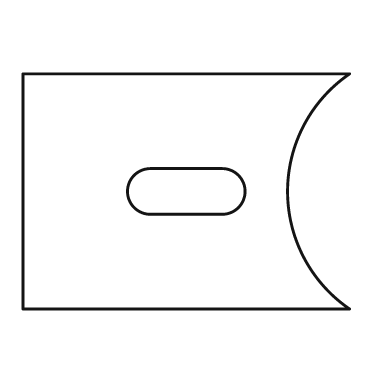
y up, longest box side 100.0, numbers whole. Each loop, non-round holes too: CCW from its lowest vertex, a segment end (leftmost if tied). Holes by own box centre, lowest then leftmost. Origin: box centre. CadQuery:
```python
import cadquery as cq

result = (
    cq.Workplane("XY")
    .moveTo(-50.0, -36.0)
    .lineTo(50.0, -36.0)
    .threePointArc((31.0, 0.0), (50.0, 36.0))
    .lineTo(-50.0, 36.0)
    .close()
    .moveTo(-11.0, -7.0)
    .lineTo(11.0, -7.0)
    .threePointArc((18.0, 0.0), (11.0, 7.0))
    .lineTo(-11.0, 7.0)
    .threePointArc((-18.0, 0.0), (-11.0, -7.0))
    .close()
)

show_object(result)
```